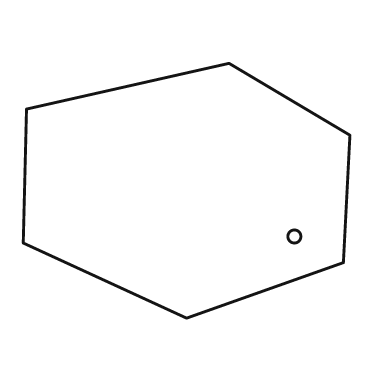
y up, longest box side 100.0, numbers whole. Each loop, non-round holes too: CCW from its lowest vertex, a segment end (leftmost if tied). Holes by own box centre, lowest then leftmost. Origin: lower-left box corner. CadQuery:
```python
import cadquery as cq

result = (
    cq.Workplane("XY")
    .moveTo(50.0, 0.0)
    .lineTo(98.0, 17.0)
    .lineTo(100.0, 56.0)
    .lineTo(63.0, 78.0)
    .lineTo(1.0, 64.0)
    .lineTo(0.0, 23.0)
    .close()
    .moveTo(83.0, 25.0)
    .circle(2.0)
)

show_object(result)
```